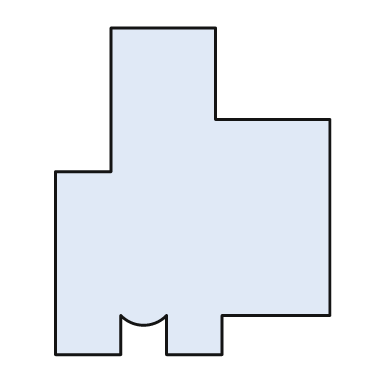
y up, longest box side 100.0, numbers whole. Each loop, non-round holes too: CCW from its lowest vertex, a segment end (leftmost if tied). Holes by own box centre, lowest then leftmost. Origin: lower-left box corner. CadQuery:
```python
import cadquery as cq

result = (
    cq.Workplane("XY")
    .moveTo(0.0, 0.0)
    .lineTo(20.0, 0.0)
    .lineTo(20.0, 12.0)
    .threePointArc((27.0, 9.0), (34.0, 12.0))
    .lineTo(34.0, 0.0)
    .lineTo(51.0, 0.0)
    .lineTo(51.0, 12.0)
    .lineTo(84.0, 12.0)
    .lineTo(84.0, 72.0)
    .lineTo(49.0, 72.0)
    .lineTo(49.0, 100.0)
    .lineTo(17.0, 100.0)
    .lineTo(17.0, 56.0)
    .lineTo(0.0, 56.0)
    .close()
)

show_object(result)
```